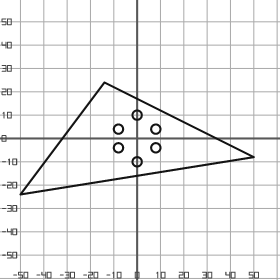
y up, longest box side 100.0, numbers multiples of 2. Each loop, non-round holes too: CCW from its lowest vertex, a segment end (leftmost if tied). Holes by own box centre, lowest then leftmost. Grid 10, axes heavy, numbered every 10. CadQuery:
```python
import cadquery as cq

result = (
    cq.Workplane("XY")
    .moveTo(-50.0, -24.0)
    .lineTo(50.0, -8.0)
    .lineTo(-14.0, 24.0)
    .close()
    .moveTo(0.0, -10.0)
    .circle(2.0)
    .moveTo(-8.0, -4.0)
    .circle(2.0)
    .moveTo(8.0, -4.0)
    .circle(2.0)
    .moveTo(-8.0, 4.0)
    .circle(2.0)
    .moveTo(8.0, 4.0)
    .circle(2.0)
    .moveTo(0.0, 10.0)
    .circle(2.0)
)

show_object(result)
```